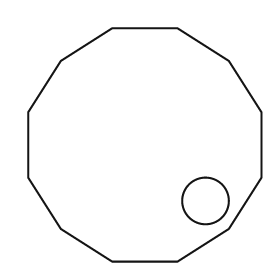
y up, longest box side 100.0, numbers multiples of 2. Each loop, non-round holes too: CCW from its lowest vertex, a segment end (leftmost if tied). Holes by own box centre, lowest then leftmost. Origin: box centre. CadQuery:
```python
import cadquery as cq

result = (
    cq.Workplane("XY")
    .moveTo(-14.0, -50.0)
    .lineTo(14.0, -50.0)
    .lineTo(36.0, -36.0)
    .lineTo(50.0, -14.0)
    .lineTo(50.0, 14.0)
    .lineTo(36.0, 36.0)
    .lineTo(14.0, 50.0)
    .lineTo(-14.0, 50.0)
    .lineTo(-36.0, 36.0)
    .lineTo(-50.0, 14.0)
    .lineTo(-50.0, -14.0)
    .lineTo(-36.0, -36.0)
    .close()
    .moveTo(26.0, -24.0)
    .circle(10.0)
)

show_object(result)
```